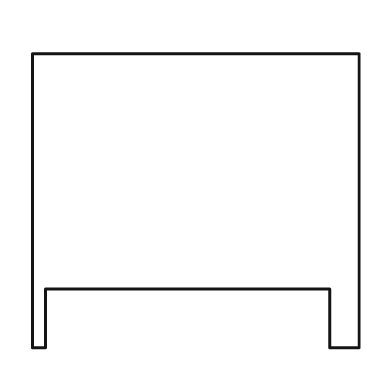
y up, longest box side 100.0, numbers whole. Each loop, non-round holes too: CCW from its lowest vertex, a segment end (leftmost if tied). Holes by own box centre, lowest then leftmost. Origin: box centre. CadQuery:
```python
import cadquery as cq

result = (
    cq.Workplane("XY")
    .moveTo(-50.0, -45.0)
    .lineTo(-46.0, -45.0)
    .lineTo(-46.0, -27.0)
    .lineTo(41.0, -27.0)
    .lineTo(41.0, -45.0)
    .lineTo(50.0, -45.0)
    .lineTo(50.0, 45.0)
    .lineTo(-50.0, 45.0)
    .close()
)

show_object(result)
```